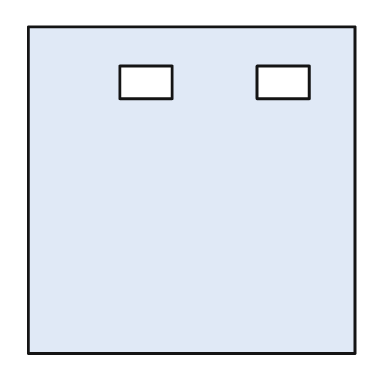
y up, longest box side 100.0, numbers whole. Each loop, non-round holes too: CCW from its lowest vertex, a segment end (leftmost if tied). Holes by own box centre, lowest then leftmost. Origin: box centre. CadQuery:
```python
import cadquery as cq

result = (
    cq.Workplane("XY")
    .moveTo(-50.0, -50.0)
    .lineTo(50.0, -50.0)
    .lineTo(50.0, 50.0)
    .lineTo(-50.0, 50.0)
    .close()
    .moveTo(-22.0, 28.0)
    .lineTo(-6.0, 28.0)
    .lineTo(-6.0, 38.0)
    .lineTo(-22.0, 38.0)
    .close()
    .moveTo(20.0, 28.0)
    .lineTo(36.0, 28.0)
    .lineTo(36.0, 38.0)
    .lineTo(20.0, 38.0)
    .close()
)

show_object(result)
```